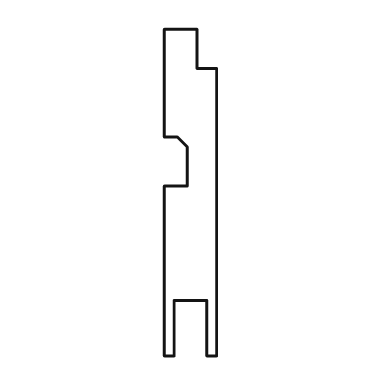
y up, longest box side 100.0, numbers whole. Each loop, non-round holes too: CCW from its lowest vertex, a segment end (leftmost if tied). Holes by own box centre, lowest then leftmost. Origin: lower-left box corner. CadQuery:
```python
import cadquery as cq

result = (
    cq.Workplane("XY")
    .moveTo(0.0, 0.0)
    .lineTo(3.0, 0.0)
    .lineTo(3.0, 17.0)
    .lineTo(13.0, 17.0)
    .lineTo(13.0, 0.0)
    .lineTo(16.0, 0.0)
    .lineTo(16.0, 88.0)
    .lineTo(10.0, 88.0)
    .lineTo(10.0, 100.0)
    .lineTo(0.0, 100.0)
    .lineTo(0.0, 67.0)
    .lineTo(4.0, 67.0)
    .lineTo(7.0, 64.0)
    .lineTo(7.0, 52.0)
    .lineTo(0.0, 52.0)
    .close()
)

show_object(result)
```